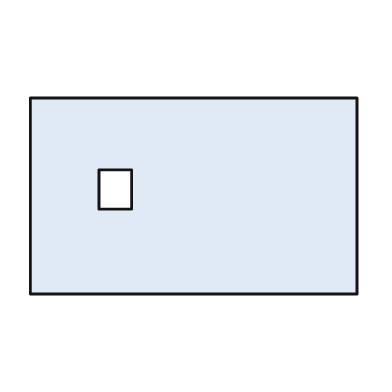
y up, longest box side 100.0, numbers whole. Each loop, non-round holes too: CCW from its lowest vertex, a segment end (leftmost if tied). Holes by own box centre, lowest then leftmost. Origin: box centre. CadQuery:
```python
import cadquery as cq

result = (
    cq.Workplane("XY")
    .moveTo(-50.0, -30.0)
    .lineTo(50.0, -30.0)
    .lineTo(50.0, 30.0)
    .lineTo(-50.0, 30.0)
    .close()
    .moveTo(-29.0, -4.0)
    .lineTo(-19.0, -4.0)
    .lineTo(-19.0, 8.0)
    .lineTo(-29.0, 8.0)
    .close()
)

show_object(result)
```